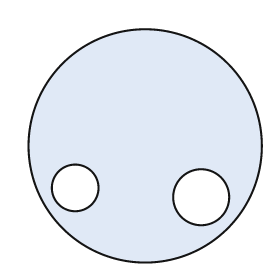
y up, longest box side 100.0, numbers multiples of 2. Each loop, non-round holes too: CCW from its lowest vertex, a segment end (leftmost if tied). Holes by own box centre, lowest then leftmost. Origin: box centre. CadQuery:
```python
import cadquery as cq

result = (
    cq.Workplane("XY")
    .moveTo(0.0, 0.0)
    .circle(50.0)
    .moveTo(24.0, -22.0)
    .circle(12.0)
    .moveTo(-30.0, -18.0)
    .circle(10.0)
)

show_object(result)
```